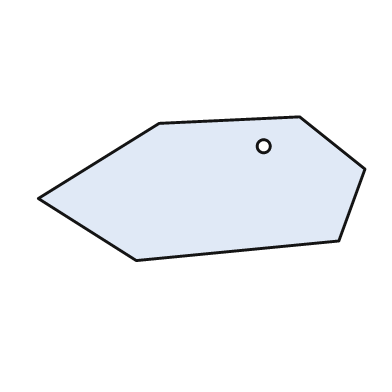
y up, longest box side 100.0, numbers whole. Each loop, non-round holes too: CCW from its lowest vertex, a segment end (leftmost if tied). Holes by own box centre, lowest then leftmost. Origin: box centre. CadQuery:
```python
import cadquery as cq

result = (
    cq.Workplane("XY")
    .moveTo(-20.0, -22.0)
    .lineTo(42.0, -16.0)
    .lineTo(50.0, 6.0)
    .lineTo(30.0, 22.0)
    .lineTo(-13.0, 20.0)
    .lineTo(-50.0, -3.0)
    .close()
    .moveTo(19.0, 13.0)
    .circle(2.0)
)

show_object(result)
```